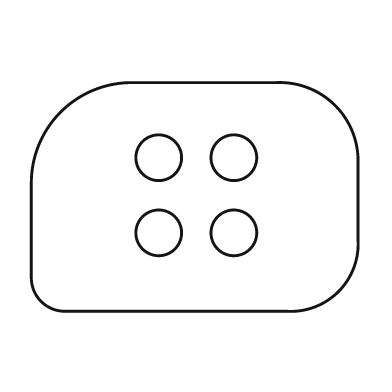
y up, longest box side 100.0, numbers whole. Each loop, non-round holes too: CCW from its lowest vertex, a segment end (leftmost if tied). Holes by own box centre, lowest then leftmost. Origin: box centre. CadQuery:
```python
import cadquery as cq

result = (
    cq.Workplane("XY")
    .moveTo(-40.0, -35.0)
    .lineTo(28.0, -35.0)
    .threePointArc((44.0, -29.0), (50.0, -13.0))
    .lineTo(50.0, 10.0)
    .threePointArc((43.0, 28.0), (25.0, 35.0))
    .lineTo(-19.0, 35.0)
    .threePointArc((-41.0, 26.0), (-50.0, 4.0))
    .lineTo(-50.0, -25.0)
    .threePointArc((-47.0, -32.0), (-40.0, -35.0))
    .close()
    .moveTo(-11.0, -11.0)
    .circle(7.0)
    .moveTo(12.0, -11.0)
    .circle(7.0)
    .moveTo(-11.0, 12.0)
    .circle(7.0)
    .moveTo(12.0, 12.0)
    .circle(7.0)
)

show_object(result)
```